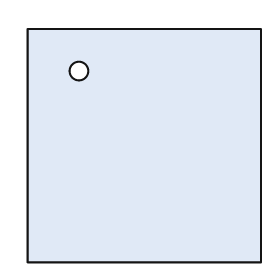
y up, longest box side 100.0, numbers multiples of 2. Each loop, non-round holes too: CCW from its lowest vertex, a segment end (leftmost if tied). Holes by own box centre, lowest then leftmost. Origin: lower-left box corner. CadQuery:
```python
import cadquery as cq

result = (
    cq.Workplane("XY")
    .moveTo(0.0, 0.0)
    .lineTo(100.0, 0.0)
    .lineTo(100.0, 100.0)
    .lineTo(0.0, 100.0)
    .close()
    .moveTo(22.0, 82.0)
    .circle(4.0)
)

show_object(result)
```